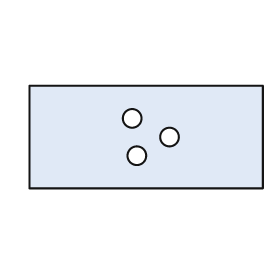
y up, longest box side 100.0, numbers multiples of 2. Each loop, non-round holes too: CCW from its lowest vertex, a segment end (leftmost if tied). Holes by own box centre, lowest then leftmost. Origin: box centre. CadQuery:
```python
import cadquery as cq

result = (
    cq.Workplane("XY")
    .moveTo(-50.0, -22.0)
    .lineTo(50.0, -22.0)
    .lineTo(50.0, 22.0)
    .lineTo(-50.0, 22.0)
    .close()
    .moveTo(-4.0, -8.0)
    .circle(4.0)
    .moveTo(10.0, 0.0)
    .circle(4.0)
    .moveTo(-6.0, 8.0)
    .circle(4.0)
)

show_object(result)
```